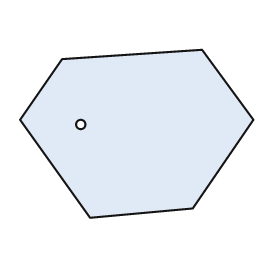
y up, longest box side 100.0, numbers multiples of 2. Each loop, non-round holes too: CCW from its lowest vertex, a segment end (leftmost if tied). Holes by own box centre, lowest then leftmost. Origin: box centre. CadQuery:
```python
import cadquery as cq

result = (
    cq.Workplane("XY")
    .moveTo(-20.0, -36.0)
    .lineTo(24.0, -32.0)
    .lineTo(50.0, 6.0)
    .lineTo(28.0, 36.0)
    .lineTo(-32.0, 32.0)
    .lineTo(-50.0, 6.0)
    .close()
    .moveTo(-24.0, 4.0)
    .circle(2.0)
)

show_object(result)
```